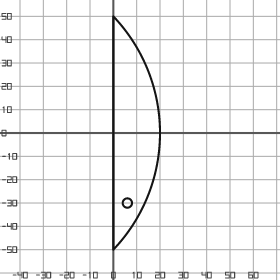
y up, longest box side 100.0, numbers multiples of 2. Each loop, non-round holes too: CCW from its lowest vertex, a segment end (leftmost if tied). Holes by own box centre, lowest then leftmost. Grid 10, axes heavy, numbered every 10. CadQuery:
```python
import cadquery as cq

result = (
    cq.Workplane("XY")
    .moveTo(0.0, -50.0)
    .threePointArc((20.0, 0.0), (0.0, 50.0))
    .close()
    .moveTo(6.0, -30.0)
    .circle(2.0)
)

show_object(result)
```